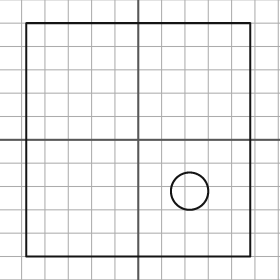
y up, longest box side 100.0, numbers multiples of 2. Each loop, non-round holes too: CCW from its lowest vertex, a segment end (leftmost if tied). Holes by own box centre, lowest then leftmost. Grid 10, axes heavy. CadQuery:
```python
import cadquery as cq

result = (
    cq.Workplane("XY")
    .moveTo(-48.0, -50.0)
    .lineTo(48.0, -50.0)
    .lineTo(48.0, 50.0)
    .lineTo(-48.0, 50.0)
    .close()
    .moveTo(22.0, -22.0)
    .circle(8.0)
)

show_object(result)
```